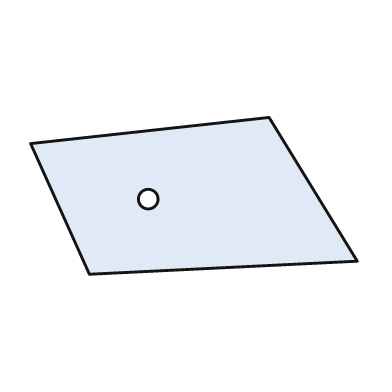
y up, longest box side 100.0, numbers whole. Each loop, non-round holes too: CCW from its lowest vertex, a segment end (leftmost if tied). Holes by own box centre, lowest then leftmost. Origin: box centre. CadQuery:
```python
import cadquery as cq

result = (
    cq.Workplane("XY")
    .moveTo(-32.0, -24.0)
    .lineTo(50.0, -20.0)
    .lineTo(23.0, 24.0)
    .lineTo(-50.0, 16.0)
    .close()
    .moveTo(-14.0, -1.0)
    .circle(3.0)
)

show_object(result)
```